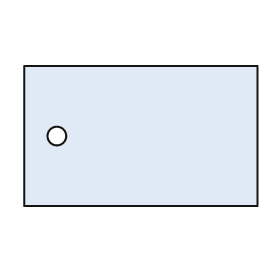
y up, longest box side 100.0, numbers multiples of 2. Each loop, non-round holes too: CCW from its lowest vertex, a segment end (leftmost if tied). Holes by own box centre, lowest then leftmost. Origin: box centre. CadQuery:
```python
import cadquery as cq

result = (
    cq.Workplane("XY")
    .moveTo(-50.0, -30.0)
    .lineTo(50.0, -30.0)
    .lineTo(50.0, 30.0)
    .lineTo(-50.0, 30.0)
    .close()
    .moveTo(-36.0, 0.0)
    .circle(4.0)
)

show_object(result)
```